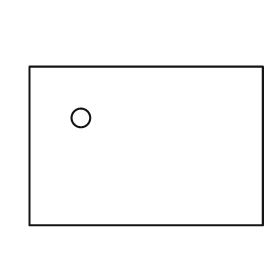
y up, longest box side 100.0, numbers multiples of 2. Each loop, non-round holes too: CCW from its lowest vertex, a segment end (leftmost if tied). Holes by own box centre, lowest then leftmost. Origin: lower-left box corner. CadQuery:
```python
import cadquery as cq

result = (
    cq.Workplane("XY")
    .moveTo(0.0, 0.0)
    .lineTo(100.0, 0.0)
    .lineTo(100.0, 68.0)
    .lineTo(0.0, 68.0)
    .close()
    .moveTo(22.0, 46.0)
    .circle(4.0)
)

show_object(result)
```